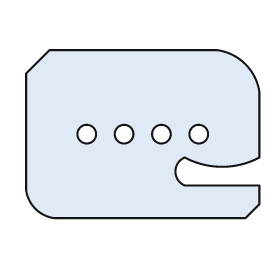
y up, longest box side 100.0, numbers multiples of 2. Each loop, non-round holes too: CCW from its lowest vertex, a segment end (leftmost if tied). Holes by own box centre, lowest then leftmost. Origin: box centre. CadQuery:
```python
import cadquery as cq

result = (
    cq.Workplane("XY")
    .moveTo(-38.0, -36.0)
    .lineTo(44.0, -36.0)
    .lineTo(50.0, -30.0)
    .lineTo(50.0, -22.0)
    .lineTo(18.0, -22.0)
    .threePointArc((14.0, -16.0), (18.0, -10.0))
    .threePointArc((34.0, -14.0), (50.0, -10.0))
    .lineTo(50.0, 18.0)
    .threePointArc((44.0, 30.0), (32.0, 36.0))
    .lineTo(-40.0, 36.0)
    .lineTo(-50.0, 26.0)
    .lineTo(-50.0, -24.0)
    .threePointArc((-46.0, -32.0), (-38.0, -36.0))
    .close()
    .moveTo(-24.0, 0.0)
    .circle(4.0)
    .moveTo(-8.0, 0.0)
    .circle(4.0)
    .moveTo(8.0, 0.0)
    .circle(4.0)
    .moveTo(24.0, 0.0)
    .circle(4.0)
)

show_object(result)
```